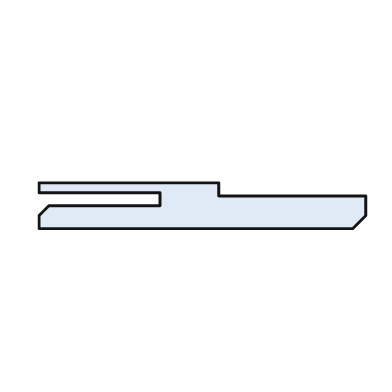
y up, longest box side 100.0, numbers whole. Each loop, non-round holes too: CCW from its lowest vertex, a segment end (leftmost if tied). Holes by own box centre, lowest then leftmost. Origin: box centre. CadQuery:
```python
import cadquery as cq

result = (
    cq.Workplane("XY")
    .moveTo(-50.0, -7.0)
    .lineTo(46.0, -7.0)
    .lineTo(50.0, -3.0)
    .lineTo(50.0, 3.0)
    .lineTo(5.0, 3.0)
    .lineTo(5.0, 7.0)
    .lineTo(-50.0, 7.0)
    .lineTo(-50.0, 4.0)
    .lineTo(-13.0, 4.0)
    .lineTo(-13.0, 0.0)
    .lineTo(-47.0, 0.0)
    .lineTo(-50.0, -3.0)
    .close()
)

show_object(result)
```